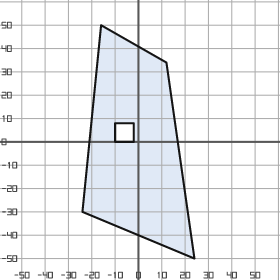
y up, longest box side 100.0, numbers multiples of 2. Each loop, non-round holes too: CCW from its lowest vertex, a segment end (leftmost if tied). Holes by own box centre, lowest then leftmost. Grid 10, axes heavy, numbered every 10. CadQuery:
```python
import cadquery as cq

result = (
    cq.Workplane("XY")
    .moveTo(24.0, -50.0)
    .lineTo(12.0, 34.0)
    .lineTo(-16.0, 50.0)
    .lineTo(-24.0, -30.0)
    .close()
    .moveTo(-10.0, 0.0)
    .lineTo(-2.0, 0.0)
    .lineTo(-2.0, 8.0)
    .lineTo(-10.0, 8.0)
    .close()
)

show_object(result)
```